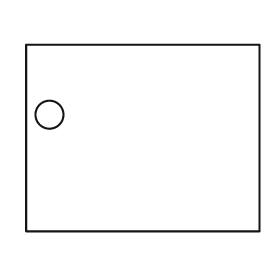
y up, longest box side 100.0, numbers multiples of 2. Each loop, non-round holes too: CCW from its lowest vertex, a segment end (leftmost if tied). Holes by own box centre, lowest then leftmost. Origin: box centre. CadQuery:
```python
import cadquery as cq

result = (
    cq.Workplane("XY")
    .moveTo(-50.0, -40.0)
    .lineTo(50.0, -40.0)
    .lineTo(50.0, 40.0)
    .lineTo(-50.0, 40.0)
    .close()
    .moveTo(-40.0, 10.0)
    .circle(6.0)
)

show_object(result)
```